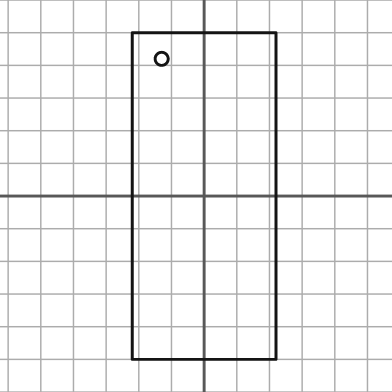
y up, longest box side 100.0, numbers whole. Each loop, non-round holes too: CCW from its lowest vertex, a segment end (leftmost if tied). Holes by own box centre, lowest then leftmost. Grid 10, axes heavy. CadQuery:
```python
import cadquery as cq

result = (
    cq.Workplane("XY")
    .moveTo(-22.0, -50.0)
    .lineTo(22.0, -50.0)
    .lineTo(22.0, 50.0)
    .lineTo(-22.0, 50.0)
    .close()
    .moveTo(-13.0, 42.0)
    .circle(2.0)
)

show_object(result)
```